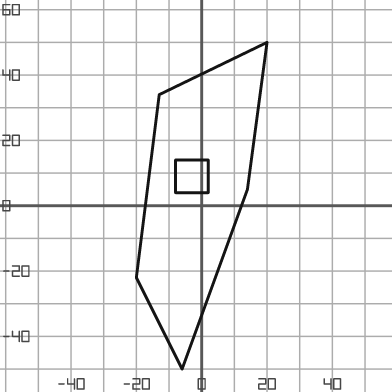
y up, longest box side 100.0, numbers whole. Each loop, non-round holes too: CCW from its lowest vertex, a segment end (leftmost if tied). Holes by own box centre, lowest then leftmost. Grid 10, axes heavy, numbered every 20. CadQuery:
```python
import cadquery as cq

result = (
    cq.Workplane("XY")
    .moveTo(-6.0, -50.0)
    .lineTo(14.0, 5.0)
    .lineTo(20.0, 50.0)
    .lineTo(-13.0, 34.0)
    .lineTo(-20.0, -22.0)
    .close()
    .moveTo(-8.0, 4.0)
    .lineTo(2.0, 4.0)
    .lineTo(2.0, 14.0)
    .lineTo(-8.0, 14.0)
    .close()
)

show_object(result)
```